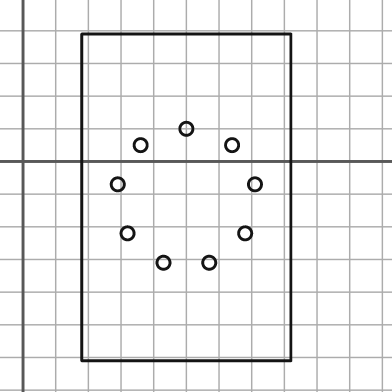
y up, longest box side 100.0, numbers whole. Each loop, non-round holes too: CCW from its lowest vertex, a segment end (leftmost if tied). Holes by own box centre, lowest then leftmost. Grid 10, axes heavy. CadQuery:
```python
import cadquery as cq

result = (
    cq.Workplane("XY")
    .moveTo(18.0, -61.0)
    .lineTo(82.0, -61.0)
    .lineTo(82.0, 39.0)
    .lineTo(18.0, 39.0)
    .close()
    .moveTo(43.0, -31.0)
    .circle(2.0)
    .moveTo(57.0, -31.0)
    .circle(2.0)
    .moveTo(32.0, -22.0)
    .circle(2.0)
    .moveTo(68.0, -22.0)
    .circle(2.0)
    .moveTo(29.0, -7.0)
    .circle(2.0)
    .moveTo(71.0, -7.0)
    .circle(2.0)
    .moveTo(36.0, 5.0)
    .circle(2.0)
    .moveTo(64.0, 5.0)
    .circle(2.0)
    .moveTo(50.0, 10.0)
    .circle(2.0)
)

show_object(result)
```